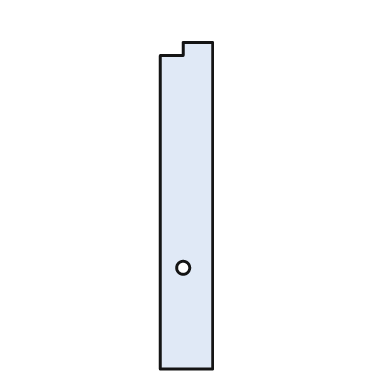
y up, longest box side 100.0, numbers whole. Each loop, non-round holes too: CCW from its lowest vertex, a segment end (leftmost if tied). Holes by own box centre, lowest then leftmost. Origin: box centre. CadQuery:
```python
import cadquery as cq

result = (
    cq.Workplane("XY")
    .moveTo(-8.0, -50.0)
    .lineTo(8.0, -50.0)
    .lineTo(8.0, 50.0)
    .lineTo(-1.0, 50.0)
    .lineTo(-1.0, 46.0)
    .lineTo(-8.0, 46.0)
    .close()
    .moveTo(-1.0, -19.0)
    .circle(2.0)
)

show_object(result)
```